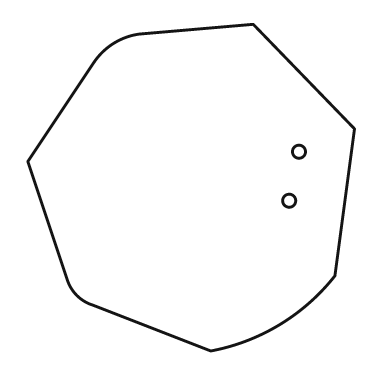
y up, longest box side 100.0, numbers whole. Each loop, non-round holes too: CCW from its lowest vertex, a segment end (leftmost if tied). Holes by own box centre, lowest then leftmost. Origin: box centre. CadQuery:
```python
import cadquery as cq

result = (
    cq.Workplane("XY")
    .moveTo(6.0, -50.0)
    .threePointArc((27.0, -42.0), (44.0, -27.0))
    .lineTo(50.0, 18.0)
    .lineTo(19.0, 50.0)
    .lineTo(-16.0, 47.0)
    .threePointArc((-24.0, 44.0), (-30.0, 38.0))
    .lineTo(-50.0, 8.0)
    .lineTo(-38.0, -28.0)
    .threePointArc((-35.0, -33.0), (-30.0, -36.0))
    .close()
    .moveTo(30.0, -4.0)
    .circle(2.0)
    .moveTo(33.0, 11.0)
    .circle(2.0)
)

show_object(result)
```